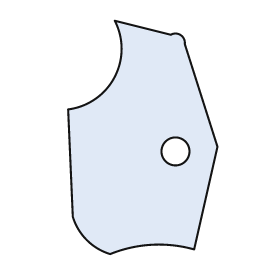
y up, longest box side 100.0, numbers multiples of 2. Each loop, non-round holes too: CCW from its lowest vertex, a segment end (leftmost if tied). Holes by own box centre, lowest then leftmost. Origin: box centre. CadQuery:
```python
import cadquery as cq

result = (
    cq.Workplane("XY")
    .moveTo(-14.0, -50.0)
    .threePointArc((4.0, -46.0), (22.0, -48.0))
    .lineTo(32.0, -4.0)
    .lineTo(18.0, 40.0)
    .threePointArc((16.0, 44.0), (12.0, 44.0))
    .lineTo(-12.0, 50.0)
    .threePointArc((-12.0, 26.0), (-32.0, 12.0))
    .lineTo(-30.0, -34.0)
    .threePointArc((-24.0, -44.0), (-14.0, -50.0))
    .close()
    .moveTo(14.0, -6.0)
    .circle(6.0)
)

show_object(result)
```